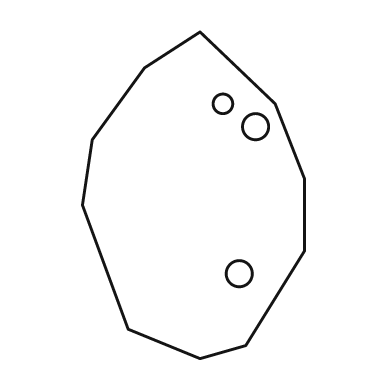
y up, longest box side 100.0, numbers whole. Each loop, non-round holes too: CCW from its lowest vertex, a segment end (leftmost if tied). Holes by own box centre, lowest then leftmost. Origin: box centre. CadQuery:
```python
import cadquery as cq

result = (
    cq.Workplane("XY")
    .moveTo(2.0, -50.0)
    .lineTo(16.0, -46.0)
    .lineTo(34.0, -17.0)
    .lineTo(34.0, 5.0)
    .lineTo(25.0, 28.0)
    .lineTo(2.0, 50.0)
    .lineTo(-15.0, 39.0)
    .lineTo(-31.0, 17.0)
    .lineTo(-34.0, -3.0)
    .lineTo(-20.0, -41.0)
    .close()
    .moveTo(14.0, -24.0)
    .circle(4.0)
    .moveTo(19.0, 21.0)
    .circle(4.0)
    .moveTo(9.0, 28.0)
    .circle(3.0)
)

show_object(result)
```